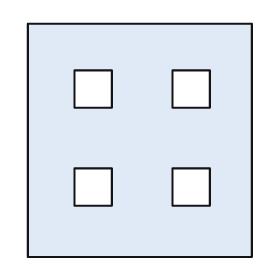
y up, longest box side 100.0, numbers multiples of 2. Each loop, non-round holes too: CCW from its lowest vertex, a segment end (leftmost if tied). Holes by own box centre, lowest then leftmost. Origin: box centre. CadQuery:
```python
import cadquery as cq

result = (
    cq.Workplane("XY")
    .moveTo(-48.0, -50.0)
    .lineTo(48.0, -50.0)
    .lineTo(48.0, 50.0)
    .lineTo(-48.0, 50.0)
    .close()
    .moveTo(-28.0, -28.0)
    .lineTo(-12.0, -28.0)
    .lineTo(-12.0, -12.0)
    .lineTo(-28.0, -12.0)
    .close()
    .moveTo(14.0, -28.0)
    .lineTo(30.0, -28.0)
    .lineTo(30.0, -12.0)
    .lineTo(14.0, -12.0)
    .close()
    .moveTo(-28.0, 14.0)
    .lineTo(-12.0, 14.0)
    .lineTo(-12.0, 30.0)
    .lineTo(-28.0, 30.0)
    .close()
    .moveTo(14.0, 14.0)
    .lineTo(30.0, 14.0)
    .lineTo(30.0, 30.0)
    .lineTo(14.0, 30.0)
    .close()
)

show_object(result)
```